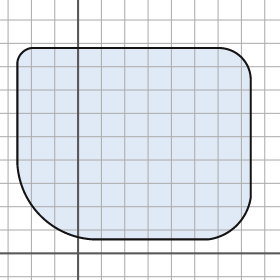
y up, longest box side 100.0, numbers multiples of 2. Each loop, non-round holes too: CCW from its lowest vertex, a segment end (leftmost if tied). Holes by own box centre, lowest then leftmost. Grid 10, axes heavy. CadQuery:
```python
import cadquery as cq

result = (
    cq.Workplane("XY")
    .moveTo(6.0, 6.0)
    .lineTo(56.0, 6.0)
    .threePointArc((68.0, 12.0), (74.0, 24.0))
    .lineTo(74.0, 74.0)
    .threePointArc((70.0, 84.0), (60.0, 88.0))
    .lineTo(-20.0, 88.0)
    .threePointArc((-24.0, 86.0), (-26.0, 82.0))
    .lineTo(-26.0, 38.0)
    .threePointArc((-16.0, 16.0), (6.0, 6.0))
    .close()
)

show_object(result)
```